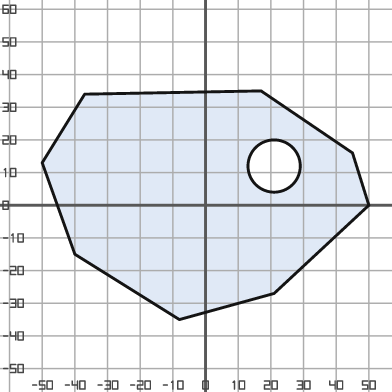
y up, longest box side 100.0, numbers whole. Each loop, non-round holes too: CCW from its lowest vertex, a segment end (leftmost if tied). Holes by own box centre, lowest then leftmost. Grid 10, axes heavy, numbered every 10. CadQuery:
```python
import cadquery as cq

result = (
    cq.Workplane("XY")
    .moveTo(-8.0, -35.0)
    .lineTo(21.0, -27.0)
    .lineTo(50.0, 0.0)
    .lineTo(45.0, 16.0)
    .lineTo(17.0, 35.0)
    .lineTo(-37.0, 34.0)
    .lineTo(-50.0, 13.0)
    .lineTo(-40.0, -15.0)
    .close()
    .moveTo(21.0, 12.0)
    .circle(8.0)
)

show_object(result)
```